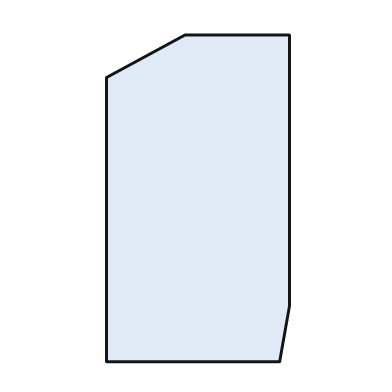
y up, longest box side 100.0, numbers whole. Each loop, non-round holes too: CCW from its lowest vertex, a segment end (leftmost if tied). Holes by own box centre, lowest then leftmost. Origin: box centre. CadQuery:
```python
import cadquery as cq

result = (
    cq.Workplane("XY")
    .moveTo(-28.0, -50.0)
    .lineTo(25.0, -50.0)
    .lineTo(28.0, -33.0)
    .lineTo(28.0, 50.0)
    .lineTo(-4.0, 50.0)
    .lineTo(-28.0, 37.0)
    .close()
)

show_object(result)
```